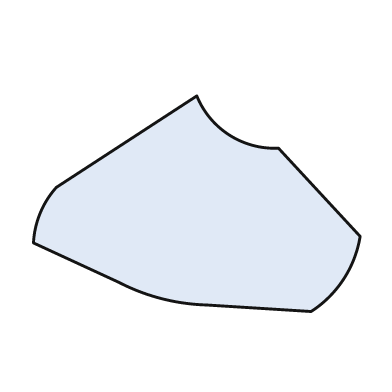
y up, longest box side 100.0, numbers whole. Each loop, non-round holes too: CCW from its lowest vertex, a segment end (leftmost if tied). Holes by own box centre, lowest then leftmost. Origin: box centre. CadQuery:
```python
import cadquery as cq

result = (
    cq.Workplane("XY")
    .moveTo(35.0, -33.0)
    .threePointArc((45.0, -23.0), (50.0, -10.0))
    .lineTo(25.0, 17.0)
    .threePointArc((10.0, 21.0), (0.0, 33.0))
    .lineTo(-43.0, 5.0)
    .threePointArc((-48.0, -3.0), (-50.0, -12.0))
    .lineTo(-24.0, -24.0)
    .threePointArc((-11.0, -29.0), (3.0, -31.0))
    .close()
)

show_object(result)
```